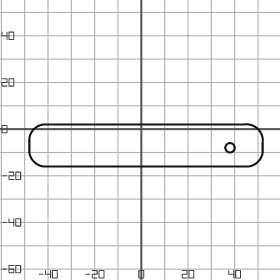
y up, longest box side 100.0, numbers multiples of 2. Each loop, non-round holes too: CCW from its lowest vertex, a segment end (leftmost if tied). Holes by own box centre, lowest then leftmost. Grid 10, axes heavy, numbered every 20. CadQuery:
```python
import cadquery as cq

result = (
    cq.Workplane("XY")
    .moveTo(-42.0, -16.0)
    .lineTo(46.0, -16.0)
    .threePointArc((50.0, -14.0), (52.0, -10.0))
    .lineTo(52.0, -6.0)
    .threePointArc((50.0, 0.0), (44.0, 2.0))
    .lineTo(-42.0, 2.0)
    .threePointArc((-46.0, 0.0), (-48.0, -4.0))
    .lineTo(-48.0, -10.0)
    .threePointArc((-46.0, -14.0), (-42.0, -16.0))
    .close()
    .moveTo(38.0, -8.0)
    .circle(2.0)
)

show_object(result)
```